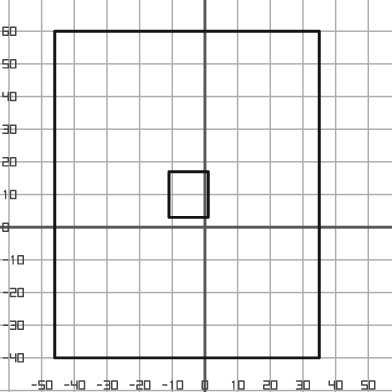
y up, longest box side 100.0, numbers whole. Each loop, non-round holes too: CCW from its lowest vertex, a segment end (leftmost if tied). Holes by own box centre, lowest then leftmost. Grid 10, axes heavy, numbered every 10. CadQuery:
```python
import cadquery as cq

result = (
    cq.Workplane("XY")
    .moveTo(-46.0, -40.0)
    .lineTo(35.0, -40.0)
    .lineTo(35.0, 60.0)
    .lineTo(-46.0, 60.0)
    .close()
    .moveTo(-11.0, 3.0)
    .lineTo(1.0, 3.0)
    .lineTo(1.0, 17.0)
    .lineTo(-11.0, 17.0)
    .close()
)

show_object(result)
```